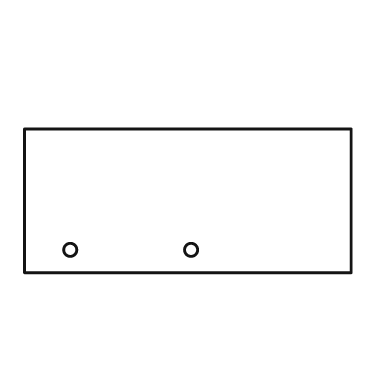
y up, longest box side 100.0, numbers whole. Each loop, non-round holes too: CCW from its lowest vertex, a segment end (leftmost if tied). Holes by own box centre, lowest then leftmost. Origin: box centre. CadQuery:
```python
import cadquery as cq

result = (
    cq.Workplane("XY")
    .moveTo(-50.0, -22.0)
    .lineTo(50.0, -22.0)
    .lineTo(50.0, 22.0)
    .lineTo(-50.0, 22.0)
    .close()
    .moveTo(-36.0, -15.0)
    .circle(2.0)
    .moveTo(1.0, -15.0)
    .circle(2.0)
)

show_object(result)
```